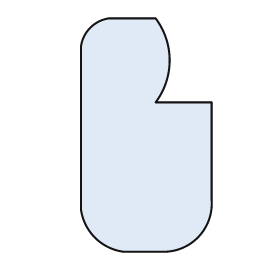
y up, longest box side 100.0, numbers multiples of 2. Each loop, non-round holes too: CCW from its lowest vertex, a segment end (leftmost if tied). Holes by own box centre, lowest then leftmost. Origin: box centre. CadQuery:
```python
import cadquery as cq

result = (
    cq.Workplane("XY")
    .moveTo(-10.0, -50.0)
    .lineTo(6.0, -50.0)
    .threePointArc((22.0, -44.0), (28.0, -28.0))
    .lineTo(28.0, 14.0)
    .lineTo(4.0, 14.0)
    .threePointArc((10.0, 32.0), (4.0, 50.0))
    .lineTo(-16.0, 50.0)
    .threePointArc((-24.0, 46.0), (-28.0, 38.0))
    .lineTo(-28.0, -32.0)
    .threePointArc((-22.0, -44.0), (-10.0, -50.0))
    .close()
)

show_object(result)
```